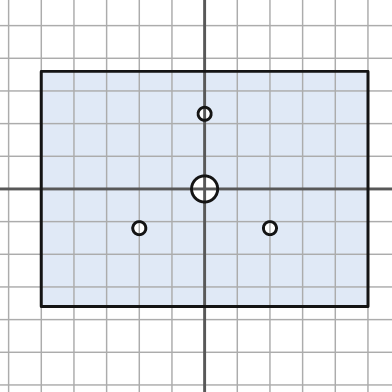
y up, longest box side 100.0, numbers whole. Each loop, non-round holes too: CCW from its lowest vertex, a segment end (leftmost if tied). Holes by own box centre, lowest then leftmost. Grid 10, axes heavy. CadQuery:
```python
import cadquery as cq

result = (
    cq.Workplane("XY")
    .moveTo(-50.0, -36.0)
    .lineTo(50.0, -36.0)
    .lineTo(50.0, 36.0)
    .lineTo(-50.0, 36.0)
    .close()
    .moveTo(-20.0, -12.0)
    .circle(2.0)
    .moveTo(20.0, -12.0)
    .circle(2.0)
    .moveTo(0.0, 0.0)
    .circle(4.0)
    .moveTo(0.0, 23.0)
    .circle(2.0)
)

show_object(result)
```